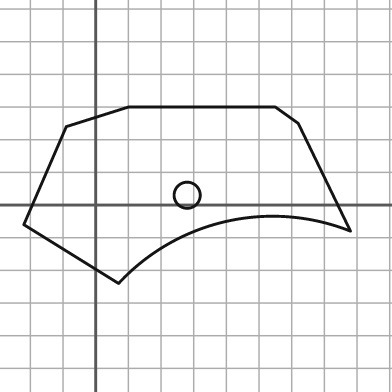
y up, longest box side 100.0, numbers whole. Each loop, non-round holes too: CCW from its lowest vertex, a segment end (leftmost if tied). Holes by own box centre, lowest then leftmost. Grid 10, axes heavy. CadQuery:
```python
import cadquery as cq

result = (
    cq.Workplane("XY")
    .moveTo(7.0, -24.0)
    .threePointArc((40.0, -5.0), (78.0, -8.0))
    .lineTo(62.0, 25.0)
    .lineTo(55.0, 30.0)
    .lineTo(10.0, 30.0)
    .lineTo(-9.0, 24.0)
    .lineTo(-22.0, -6.0)
    .close()
    .moveTo(28.0, 3.0)
    .circle(4.0)
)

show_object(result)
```